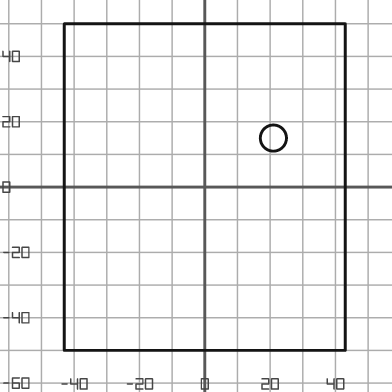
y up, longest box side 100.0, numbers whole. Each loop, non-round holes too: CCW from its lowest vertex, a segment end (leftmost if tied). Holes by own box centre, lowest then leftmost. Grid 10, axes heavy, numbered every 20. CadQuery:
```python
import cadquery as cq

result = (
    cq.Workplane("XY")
    .moveTo(-43.0, -50.0)
    .lineTo(43.0, -50.0)
    .lineTo(43.0, 50.0)
    .lineTo(-43.0, 50.0)
    .close()
    .moveTo(21.0, 15.0)
    .circle(4.0)
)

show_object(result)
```